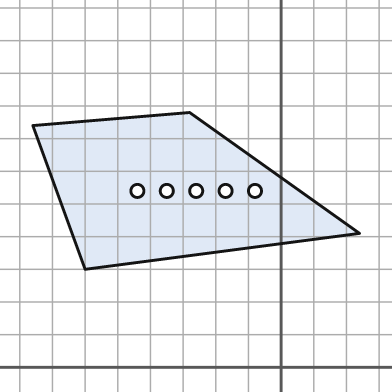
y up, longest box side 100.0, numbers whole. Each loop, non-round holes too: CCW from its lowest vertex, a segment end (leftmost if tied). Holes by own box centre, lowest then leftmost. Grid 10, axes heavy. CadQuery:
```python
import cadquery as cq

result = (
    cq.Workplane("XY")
    .moveTo(-60.0, 30.0)
    .lineTo(24.0, 41.0)
    .lineTo(-28.0, 78.0)
    .lineTo(-76.0, 74.0)
    .close()
    .moveTo(-44.0, 54.0)
    .circle(2.0)
    .moveTo(-35.0, 54.0)
    .circle(2.0)
    .moveTo(-26.0, 54.0)
    .circle(2.0)
    .moveTo(-17.0, 54.0)
    .circle(2.0)
    .moveTo(-8.0, 54.0)
    .circle(2.0)
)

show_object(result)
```